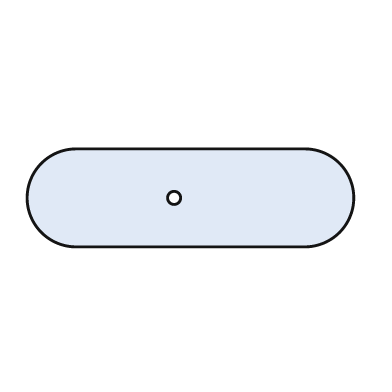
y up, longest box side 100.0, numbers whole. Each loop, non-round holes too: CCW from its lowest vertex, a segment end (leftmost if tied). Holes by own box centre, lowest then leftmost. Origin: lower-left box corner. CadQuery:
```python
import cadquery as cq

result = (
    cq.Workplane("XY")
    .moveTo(15.0, 0.0)
    .lineTo(85.0, 0.0)
    .threePointArc((100.0, 15.0), (85.0, 30.0))
    .lineTo(15.0, 30.0)
    .threePointArc((0.0, 15.0), (15.0, 0.0))
    .close()
    .moveTo(45.0, 15.0)
    .circle(2.0)
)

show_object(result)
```